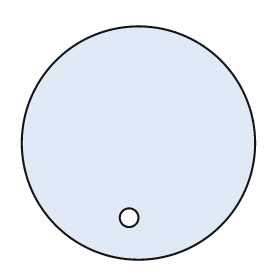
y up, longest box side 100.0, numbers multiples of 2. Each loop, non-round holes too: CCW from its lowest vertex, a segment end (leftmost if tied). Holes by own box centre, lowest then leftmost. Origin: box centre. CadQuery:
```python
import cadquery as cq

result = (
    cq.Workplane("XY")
    .moveTo(0.0, 0.0)
    .circle(50.0)
    .moveTo(-4.0, -32.0)
    .circle(4.0)
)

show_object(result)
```